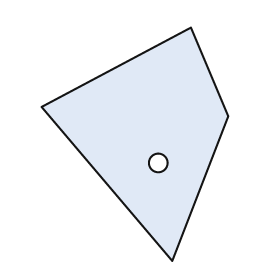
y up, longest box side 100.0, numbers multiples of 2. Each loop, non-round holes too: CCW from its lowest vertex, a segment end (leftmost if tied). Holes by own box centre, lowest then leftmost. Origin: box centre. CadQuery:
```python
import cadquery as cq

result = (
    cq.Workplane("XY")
    .moveTo(16.0, -50.0)
    .lineTo(40.0, 12.0)
    .lineTo(24.0, 50.0)
    .lineTo(-40.0, 16.0)
    .close()
    .moveTo(10.0, -8.0)
    .circle(4.0)
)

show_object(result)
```